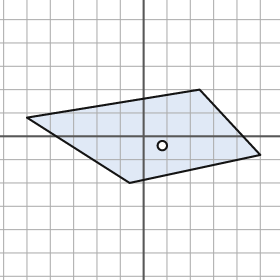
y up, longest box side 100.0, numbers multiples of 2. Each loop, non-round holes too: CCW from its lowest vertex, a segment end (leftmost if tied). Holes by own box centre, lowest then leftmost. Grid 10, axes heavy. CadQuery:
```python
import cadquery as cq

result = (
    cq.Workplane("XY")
    .moveTo(-6.0, -20.0)
    .lineTo(50.0, -8.0)
    .lineTo(24.0, 20.0)
    .lineTo(-50.0, 8.0)
    .close()
    .moveTo(8.0, -4.0)
    .circle(2.0)
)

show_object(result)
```